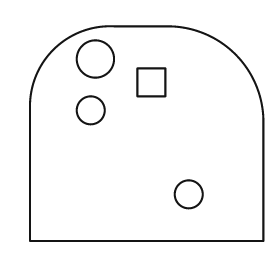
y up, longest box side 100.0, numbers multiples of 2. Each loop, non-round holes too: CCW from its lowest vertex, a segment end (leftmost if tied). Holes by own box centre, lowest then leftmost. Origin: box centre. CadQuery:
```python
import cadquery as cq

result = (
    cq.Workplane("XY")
    .moveTo(-50.0, -46.0)
    .lineTo(50.0, -46.0)
    .lineTo(50.0, 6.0)
    .threePointArc((38.0, 34.0), (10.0, 46.0))
    .lineTo(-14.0, 46.0)
    .threePointArc((-40.0, 36.0), (-50.0, 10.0))
    .close()
    .moveTo(18.0, -26.0)
    .circle(6.0)
    .moveTo(-24.0, 10.0)
    .circle(6.0)
    .moveTo(-4.0, 16.0)
    .lineTo(8.0, 16.0)
    .lineTo(8.0, 28.0)
    .lineTo(-4.0, 28.0)
    .close()
    .moveTo(-22.0, 32.0)
    .circle(8.0)
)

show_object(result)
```